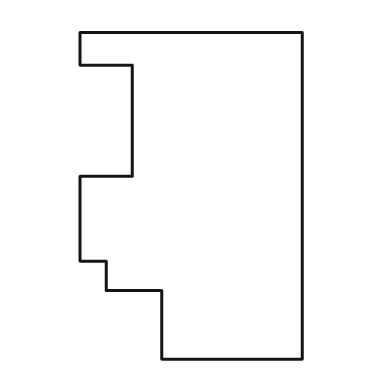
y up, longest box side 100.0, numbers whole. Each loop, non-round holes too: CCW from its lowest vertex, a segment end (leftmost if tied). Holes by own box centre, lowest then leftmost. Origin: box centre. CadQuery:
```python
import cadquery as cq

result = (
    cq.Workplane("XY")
    .moveTo(-9.0, -50.0)
    .lineTo(34.0, -50.0)
    .lineTo(34.0, 50.0)
    .lineTo(-34.0, 50.0)
    .lineTo(-34.0, 40.0)
    .lineTo(-18.0, 40.0)
    .lineTo(-18.0, 6.0)
    .lineTo(-34.0, 6.0)
    .lineTo(-34.0, -20.0)
    .lineTo(-26.0, -20.0)
    .lineTo(-26.0, -29.0)
    .lineTo(-9.0, -29.0)
    .close()
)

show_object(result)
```